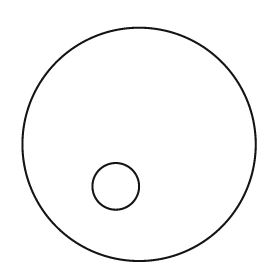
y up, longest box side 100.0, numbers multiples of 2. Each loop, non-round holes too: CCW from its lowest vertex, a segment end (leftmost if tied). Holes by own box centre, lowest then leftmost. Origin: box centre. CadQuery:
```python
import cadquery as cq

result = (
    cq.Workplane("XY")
    .moveTo(0.0, 0.0)
    .circle(50.0)
    .moveTo(-10.0, -18.0)
    .circle(10.0)
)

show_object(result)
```